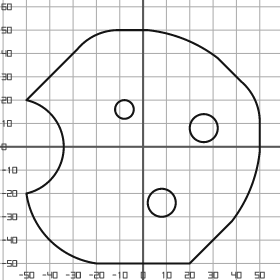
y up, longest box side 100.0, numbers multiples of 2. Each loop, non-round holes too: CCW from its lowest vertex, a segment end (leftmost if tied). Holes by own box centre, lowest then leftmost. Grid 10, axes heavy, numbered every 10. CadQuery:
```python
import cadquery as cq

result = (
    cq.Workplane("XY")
    .moveTo(-20.0, -50.0)
    .lineTo(20.0, -50.0)
    .lineTo(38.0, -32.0)
    .threePointArc((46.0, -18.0), (50.0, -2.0))
    .lineTo(50.0, 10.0)
    .threePointArc((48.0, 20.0), (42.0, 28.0))
    .lineTo(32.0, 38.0)
    .threePointArc((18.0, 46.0), (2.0, 50.0))
    .lineTo(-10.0, 50.0)
    .threePointArc((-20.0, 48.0), (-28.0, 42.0))
    .lineTo(-50.0, 20.0)
    .threePointArc((-34.0, 0.0), (-50.0, -20.0))
    .threePointArc((-40.0, -40.0), (-20.0, -50.0))
    .close()
    .moveTo(8.0, -24.0)
    .circle(6.0)
    .moveTo(26.0, 8.0)
    .circle(6.0)
    .moveTo(-8.0, 16.0)
    .circle(4.0)
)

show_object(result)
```